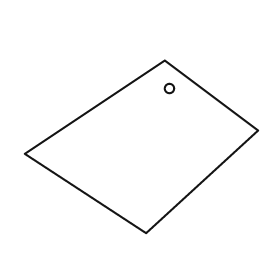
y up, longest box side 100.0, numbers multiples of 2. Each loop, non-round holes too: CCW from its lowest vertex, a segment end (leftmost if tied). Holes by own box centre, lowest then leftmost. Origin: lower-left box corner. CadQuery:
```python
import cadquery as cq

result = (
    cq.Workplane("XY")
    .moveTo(52.0, 0.0)
    .lineTo(100.0, 44.0)
    .lineTo(60.0, 74.0)
    .lineTo(0.0, 34.0)
    .close()
    .moveTo(62.0, 62.0)
    .circle(2.0)
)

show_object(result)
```